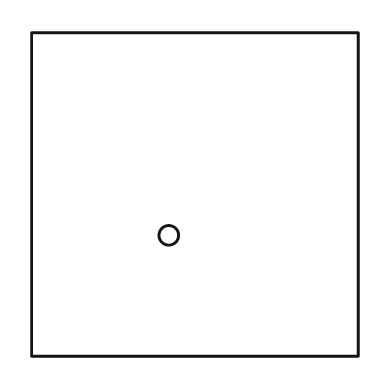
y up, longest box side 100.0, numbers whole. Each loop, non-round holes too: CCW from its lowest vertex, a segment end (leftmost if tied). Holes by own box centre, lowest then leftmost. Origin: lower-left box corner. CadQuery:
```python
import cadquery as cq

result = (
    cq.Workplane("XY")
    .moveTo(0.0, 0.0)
    .lineTo(100.0, 0.0)
    .lineTo(100.0, 99.0)
    .lineTo(0.0, 99.0)
    .close()
    .moveTo(42.0, 37.0)
    .circle(3.0)
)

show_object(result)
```